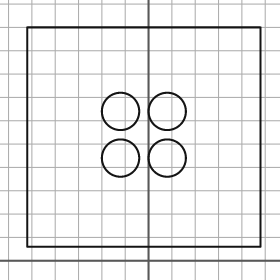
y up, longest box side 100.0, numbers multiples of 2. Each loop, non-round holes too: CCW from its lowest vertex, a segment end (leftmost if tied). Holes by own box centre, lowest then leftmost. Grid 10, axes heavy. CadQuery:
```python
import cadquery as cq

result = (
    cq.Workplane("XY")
    .moveTo(-52.0, 6.0)
    .lineTo(48.0, 6.0)
    .lineTo(48.0, 100.0)
    .lineTo(-52.0, 100.0)
    .close()
    .moveTo(-12.0, 44.0)
    .circle(8.0)
    .moveTo(8.0, 44.0)
    .circle(8.0)
    .moveTo(-12.0, 64.0)
    .circle(8.0)
    .moveTo(8.0, 64.0)
    .circle(8.0)
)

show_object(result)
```